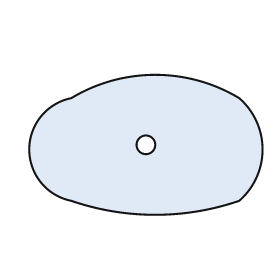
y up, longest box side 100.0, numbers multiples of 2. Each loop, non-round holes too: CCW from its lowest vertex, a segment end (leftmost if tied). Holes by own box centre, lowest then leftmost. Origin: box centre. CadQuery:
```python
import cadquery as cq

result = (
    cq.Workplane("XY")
    .moveTo(-32.0, -24.0)
    .threePointArc((4.0, -30.0), (40.0, -24.0))
    .threePointArc((50.0, -2.0), (40.0, 20.0))
    .threePointArc((4.0, 30.0), (-32.0, 20.0))
    .threePointArc((-50.0, -2.0), (-32.0, -24.0))
    .close()
    .moveTo(0.0, 0.0)
    .circle(4.0)
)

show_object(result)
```